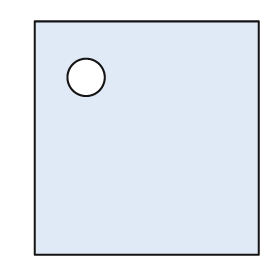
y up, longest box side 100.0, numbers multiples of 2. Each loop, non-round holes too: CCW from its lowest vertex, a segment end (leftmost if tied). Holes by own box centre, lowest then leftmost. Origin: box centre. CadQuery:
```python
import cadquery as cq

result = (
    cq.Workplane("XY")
    .moveTo(-48.0, -50.0)
    .lineTo(48.0, -50.0)
    .lineTo(48.0, 50.0)
    .lineTo(-48.0, 50.0)
    .close()
    .moveTo(-26.0, 26.0)
    .circle(8.0)
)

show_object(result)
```